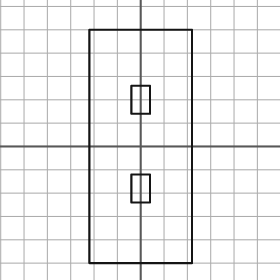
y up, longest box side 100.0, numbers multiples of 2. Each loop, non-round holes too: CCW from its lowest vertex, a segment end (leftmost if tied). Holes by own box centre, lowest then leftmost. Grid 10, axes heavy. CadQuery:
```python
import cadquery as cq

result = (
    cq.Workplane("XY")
    .moveTo(-22.0, -50.0)
    .lineTo(22.0, -50.0)
    .lineTo(22.0, 50.0)
    .lineTo(-22.0, 50.0)
    .close()
    .moveTo(-4.0, -24.0)
    .lineTo(4.0, -24.0)
    .lineTo(4.0, -12.0)
    .lineTo(-4.0, -12.0)
    .close()
    .moveTo(-4.0, 14.0)
    .lineTo(4.0, 14.0)
    .lineTo(4.0, 26.0)
    .lineTo(-4.0, 26.0)
    .close()
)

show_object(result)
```